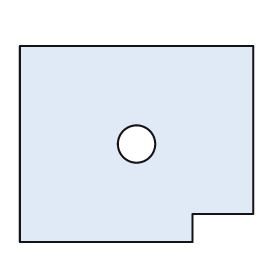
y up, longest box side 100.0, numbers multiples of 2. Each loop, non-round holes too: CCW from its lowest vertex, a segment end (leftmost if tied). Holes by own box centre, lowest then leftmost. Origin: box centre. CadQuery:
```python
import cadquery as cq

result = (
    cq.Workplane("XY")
    .moveTo(-50.0, -42.0)
    .lineTo(24.0, -42.0)
    .lineTo(24.0, -30.0)
    .lineTo(50.0, -30.0)
    .lineTo(50.0, 42.0)
    .lineTo(-50.0, 42.0)
    .close()
    .moveTo(0.0, 0.0)
    .circle(8.0)
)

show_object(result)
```